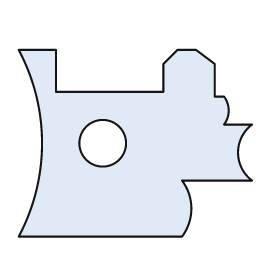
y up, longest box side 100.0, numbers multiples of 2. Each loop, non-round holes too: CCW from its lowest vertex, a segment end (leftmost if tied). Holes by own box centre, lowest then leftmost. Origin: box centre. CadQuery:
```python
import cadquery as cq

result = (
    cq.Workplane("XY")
    .moveTo(-50.0, -40.0)
    .lineTo(20.0, -40.0)
    .threePointArc((24.0, -28.0), (20.0, -16.0))
    .lineTo(50.0, -16.0)
    .threePointArc((44.0, -4.0), (50.0, 8.0))
    .lineTo(38.0, 8.0)
    .threePointArc((40.0, 14.0), (38.0, 20.0))
    .lineTo(34.0, 20.0)
    .lineTo(34.0, 34.0)
    .lineTo(26.0, 40.0)
    .lineTo(18.0, 40.0)
    .lineTo(12.0, 34.0)
    .lineTo(12.0, 22.0)
    .lineTo(-34.0, 22.0)
    .lineTo(-34.0, 40.0)
    .lineTo(-50.0, 40.0)
    .threePointArc((-40.0, 0.0), (-50.0, -40.0))
    .close()
    .moveTo(-14.0, 0.0)
    .circle(10.0)
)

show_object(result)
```